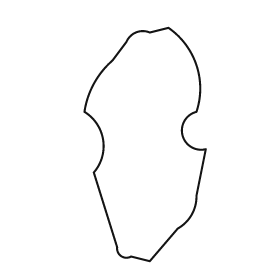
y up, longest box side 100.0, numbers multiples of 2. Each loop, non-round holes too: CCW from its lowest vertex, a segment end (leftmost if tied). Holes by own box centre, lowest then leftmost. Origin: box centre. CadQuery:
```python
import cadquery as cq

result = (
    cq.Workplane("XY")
    .moveTo(2.0, -50.0)
    .lineTo(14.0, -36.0)
    .threePointArc((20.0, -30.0), (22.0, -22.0))
    .lineTo(26.0, -2.0)
    .threePointArc((16.0, 4.0), (22.0, 14.0))
    .threePointArc((22.0, 34.0), (10.0, 50.0))
    .lineTo(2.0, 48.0)
    .threePointArc((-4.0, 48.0), (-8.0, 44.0))
    .lineTo(-14.0, 36.0)
    .threePointArc((-22.0, 26.0), (-26.0, 14.0))
    .threePointArc((-18.0, 2.0), (-22.0, -12.0))
    .lineTo(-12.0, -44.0)
    .threePointArc((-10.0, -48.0), (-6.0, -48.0))
    .close()
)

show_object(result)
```